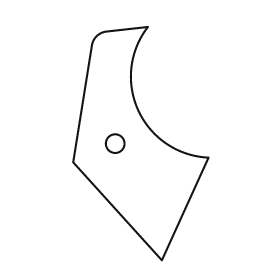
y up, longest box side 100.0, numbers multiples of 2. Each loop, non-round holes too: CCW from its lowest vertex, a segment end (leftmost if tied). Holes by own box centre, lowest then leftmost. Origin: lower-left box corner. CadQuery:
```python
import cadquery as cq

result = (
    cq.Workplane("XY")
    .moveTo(38.0, 0.0)
    .lineTo(58.0, 44.0)
    .threePointArc((28.0, 64.0), (32.0, 100.0))
    .lineTo(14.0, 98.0)
    .threePointArc((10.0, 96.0), (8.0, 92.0))
    .lineTo(0.0, 42.0)
    .close()
    .moveTo(18.0, 50.0)
    .circle(4.0)
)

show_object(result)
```